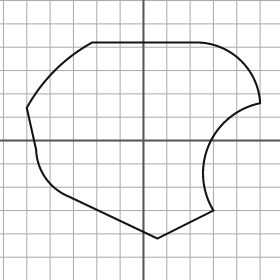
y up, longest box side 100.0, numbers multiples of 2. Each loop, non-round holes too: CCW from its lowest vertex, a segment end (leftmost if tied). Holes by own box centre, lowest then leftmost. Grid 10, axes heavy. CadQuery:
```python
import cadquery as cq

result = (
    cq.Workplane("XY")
    .moveTo(6.0, -42.0)
    .lineTo(30.0, -30.0)
    .threePointArc((28.0, -2.0), (50.0, 16.0))
    .threePointArc((42.0, 34.0), (24.0, 42.0))
    .lineTo(-22.0, 42.0)
    .threePointArc((-38.0, 30.0), (-50.0, 14.0))
    .lineTo(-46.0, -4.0)
    .threePointArc((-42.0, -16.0), (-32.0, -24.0))
    .close()
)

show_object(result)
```